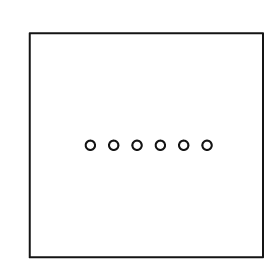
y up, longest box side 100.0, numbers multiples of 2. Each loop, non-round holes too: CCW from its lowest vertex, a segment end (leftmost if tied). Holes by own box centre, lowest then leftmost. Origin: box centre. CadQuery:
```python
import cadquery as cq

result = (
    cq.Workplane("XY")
    .moveTo(-50.0, -48.0)
    .lineTo(50.0, -48.0)
    .lineTo(50.0, 48.0)
    .lineTo(-50.0, 48.0)
    .close()
    .moveTo(-24.0, 0.0)
    .circle(2.0)
    .moveTo(-14.0, 0.0)
    .circle(2.0)
    .moveTo(-4.0, 0.0)
    .circle(2.0)
    .moveTo(6.0, 0.0)
    .circle(2.0)
    .moveTo(16.0, 0.0)
    .circle(2.0)
    .moveTo(26.0, 0.0)
    .circle(2.0)
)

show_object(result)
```